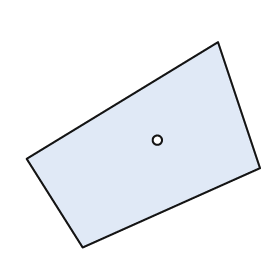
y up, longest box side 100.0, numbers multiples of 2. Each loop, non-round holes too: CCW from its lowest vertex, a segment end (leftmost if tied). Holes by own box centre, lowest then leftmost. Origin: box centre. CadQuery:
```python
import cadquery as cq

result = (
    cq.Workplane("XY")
    .moveTo(-26.0, -44.0)
    .lineTo(50.0, -10.0)
    .lineTo(32.0, 44.0)
    .lineTo(-50.0, -6.0)
    .close()
    .moveTo(6.0, 2.0)
    .circle(2.0)
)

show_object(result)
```